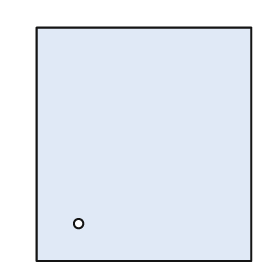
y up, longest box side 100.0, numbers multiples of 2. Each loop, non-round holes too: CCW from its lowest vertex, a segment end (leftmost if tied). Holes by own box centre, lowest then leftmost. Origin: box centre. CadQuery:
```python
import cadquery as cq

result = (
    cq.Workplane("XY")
    .moveTo(-46.0, -50.0)
    .lineTo(46.0, -50.0)
    .lineTo(46.0, 50.0)
    .lineTo(-46.0, 50.0)
    .close()
    .moveTo(-28.0, -34.0)
    .circle(2.0)
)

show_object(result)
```